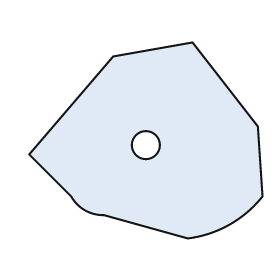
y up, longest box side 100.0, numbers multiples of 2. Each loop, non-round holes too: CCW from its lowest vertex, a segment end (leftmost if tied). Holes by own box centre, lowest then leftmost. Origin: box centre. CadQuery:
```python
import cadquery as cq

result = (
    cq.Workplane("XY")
    .moveTo(18.0, -42.0)
    .threePointArc((36.0, -36.0), (50.0, -24.0))
    .lineTo(48.0, 6.0)
    .lineTo(20.0, 42.0)
    .lineTo(-14.0, 36.0)
    .lineTo(-50.0, -6.0)
    .lineTo(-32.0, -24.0)
    .threePointArc((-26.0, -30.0), (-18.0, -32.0))
    .close()
    .moveTo(0.0, -2.0)
    .circle(6.0)
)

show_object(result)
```